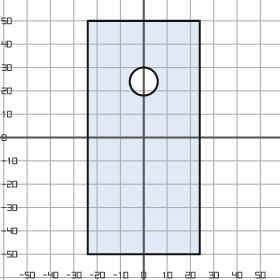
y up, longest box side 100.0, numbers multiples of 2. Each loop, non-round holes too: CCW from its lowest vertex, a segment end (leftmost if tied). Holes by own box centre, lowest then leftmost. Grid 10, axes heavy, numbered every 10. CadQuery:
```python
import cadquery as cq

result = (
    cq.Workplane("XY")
    .moveTo(-24.0, -50.0)
    .lineTo(24.0, -50.0)
    .lineTo(24.0, 50.0)
    .lineTo(-24.0, 50.0)
    .close()
    .moveTo(0.0, 24.0)
    .circle(6.0)
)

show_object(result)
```